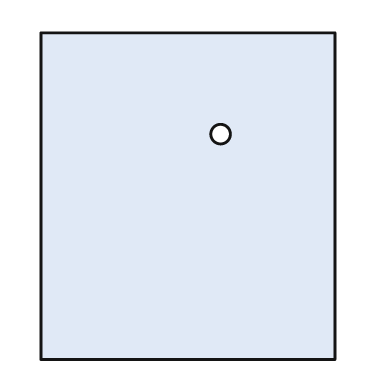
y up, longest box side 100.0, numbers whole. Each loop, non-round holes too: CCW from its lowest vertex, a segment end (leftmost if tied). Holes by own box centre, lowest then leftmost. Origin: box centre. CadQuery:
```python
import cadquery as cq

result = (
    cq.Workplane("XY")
    .moveTo(-45.0, -50.0)
    .lineTo(45.0, -50.0)
    .lineTo(45.0, 50.0)
    .lineTo(-45.0, 50.0)
    .close()
    .moveTo(10.0, 19.0)
    .circle(3.0)
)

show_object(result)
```